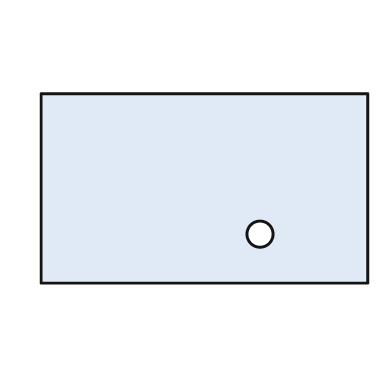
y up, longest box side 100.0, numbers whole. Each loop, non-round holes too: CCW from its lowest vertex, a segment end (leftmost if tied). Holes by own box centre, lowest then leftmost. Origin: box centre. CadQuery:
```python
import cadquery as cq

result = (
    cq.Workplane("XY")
    .moveTo(-50.0, -29.0)
    .lineTo(50.0, -29.0)
    .lineTo(50.0, 29.0)
    .lineTo(-50.0, 29.0)
    .close()
    .moveTo(17.0, -14.0)
    .circle(4.0)
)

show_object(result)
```